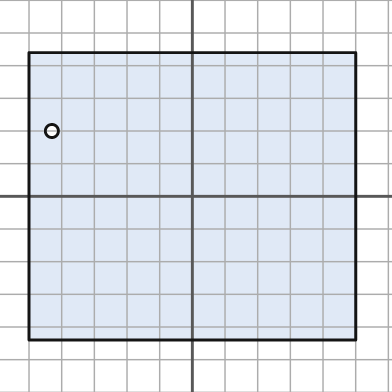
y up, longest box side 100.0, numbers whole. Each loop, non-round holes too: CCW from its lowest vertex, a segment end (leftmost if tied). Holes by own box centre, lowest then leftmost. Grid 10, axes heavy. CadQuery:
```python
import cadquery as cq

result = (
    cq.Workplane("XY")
    .moveTo(-50.0, -44.0)
    .lineTo(50.0, -44.0)
    .lineTo(50.0, 44.0)
    .lineTo(-50.0, 44.0)
    .close()
    .moveTo(-43.0, 20.0)
    .circle(2.0)
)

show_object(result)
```